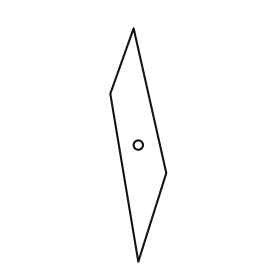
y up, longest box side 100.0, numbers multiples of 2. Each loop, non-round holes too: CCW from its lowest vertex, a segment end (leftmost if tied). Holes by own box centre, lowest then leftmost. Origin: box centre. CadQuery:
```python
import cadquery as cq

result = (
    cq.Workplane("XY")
    .moveTo(0.0, -50.0)
    .lineTo(12.0, -12.0)
    .lineTo(-2.0, 50.0)
    .lineTo(-12.0, 22.0)
    .close()
    .moveTo(0.0, 0.0)
    .circle(2.0)
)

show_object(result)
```